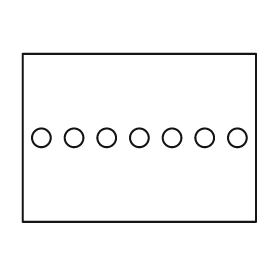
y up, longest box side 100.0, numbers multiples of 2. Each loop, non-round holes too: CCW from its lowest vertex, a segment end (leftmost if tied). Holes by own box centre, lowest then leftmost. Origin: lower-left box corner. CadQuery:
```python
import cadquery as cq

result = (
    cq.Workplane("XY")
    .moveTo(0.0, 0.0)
    .lineTo(100.0, 0.0)
    .lineTo(100.0, 72.0)
    .lineTo(0.0, 72.0)
    .close()
    .moveTo(8.0, 36.0)
    .circle(4.0)
    .moveTo(22.0, 36.0)
    .circle(4.0)
    .moveTo(36.0, 36.0)
    .circle(4.0)
    .moveTo(50.0, 36.0)
    .circle(4.0)
    .moveTo(64.0, 36.0)
    .circle(4.0)
    .moveTo(78.0, 36.0)
    .circle(4.0)
    .moveTo(92.0, 36.0)
    .circle(4.0)
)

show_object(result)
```